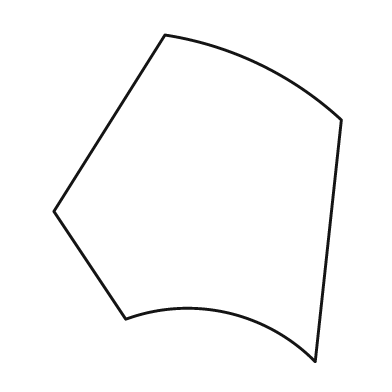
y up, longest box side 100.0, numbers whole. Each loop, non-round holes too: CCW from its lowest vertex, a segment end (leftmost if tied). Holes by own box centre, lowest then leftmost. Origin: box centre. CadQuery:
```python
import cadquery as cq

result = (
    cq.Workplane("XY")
    .moveTo(36.0, -50.0)
    .lineTo(44.0, 24.0)
    .threePointArc((19.0, 41.0), (-10.0, 50.0))
    .lineTo(-44.0, -4.0)
    .lineTo(-22.0, -37.0)
    .threePointArc((9.0, -35.0), (36.0, -50.0))
    .close()
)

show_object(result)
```